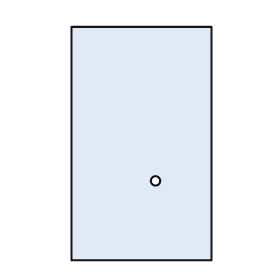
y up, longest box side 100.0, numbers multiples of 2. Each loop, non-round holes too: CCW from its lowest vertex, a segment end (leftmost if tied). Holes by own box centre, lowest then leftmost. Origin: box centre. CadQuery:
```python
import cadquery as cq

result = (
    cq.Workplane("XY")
    .moveTo(-30.0, -50.0)
    .lineTo(30.0, -50.0)
    .lineTo(30.0, 50.0)
    .lineTo(-30.0, 50.0)
    .close()
    .moveTo(6.0, -16.0)
    .circle(2.0)
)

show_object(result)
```